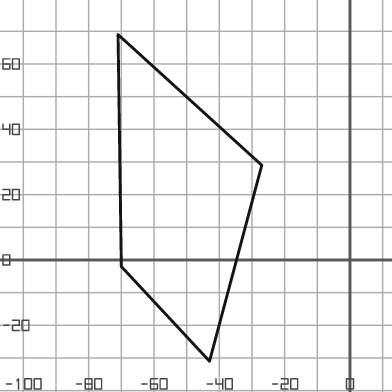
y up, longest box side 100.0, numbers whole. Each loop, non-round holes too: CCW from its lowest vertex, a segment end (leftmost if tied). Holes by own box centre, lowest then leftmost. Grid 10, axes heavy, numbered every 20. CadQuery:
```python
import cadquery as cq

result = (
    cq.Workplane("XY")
    .moveTo(-43.0, -31.0)
    .lineTo(-27.0, 29.0)
    .lineTo(-71.0, 69.0)
    .lineTo(-70.0, -2.0)
    .close()
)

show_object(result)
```